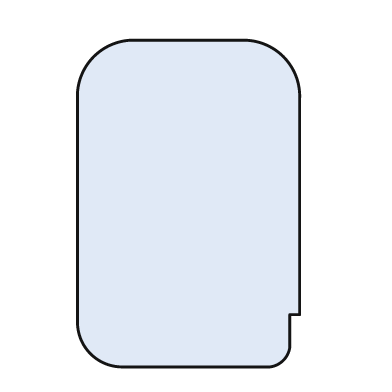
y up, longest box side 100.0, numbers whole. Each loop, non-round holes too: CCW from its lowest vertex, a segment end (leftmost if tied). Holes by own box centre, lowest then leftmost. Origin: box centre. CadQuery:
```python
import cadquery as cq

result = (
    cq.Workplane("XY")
    .moveTo(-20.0, -50.0)
    .lineTo(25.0, -50.0)
    .threePointArc((29.0, -48.0), (31.0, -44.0))
    .lineTo(31.0, -34.0)
    .lineTo(34.0, -34.0)
    .lineTo(34.0, 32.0)
    .threePointArc((29.0, 45.0), (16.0, 50.0))
    .lineTo(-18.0, 50.0)
    .threePointArc((-29.0, 45.0), (-34.0, 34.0))
    .lineTo(-34.0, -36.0)
    .threePointArc((-30.0, -46.0), (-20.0, -50.0))
    .close()
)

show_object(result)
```